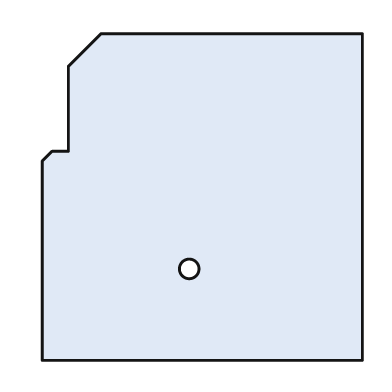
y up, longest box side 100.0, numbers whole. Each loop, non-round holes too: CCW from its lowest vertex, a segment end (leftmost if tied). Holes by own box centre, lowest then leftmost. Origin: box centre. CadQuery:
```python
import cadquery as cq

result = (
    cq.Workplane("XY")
    .moveTo(-49.0, -50.0)
    .lineTo(49.0, -50.0)
    .lineTo(49.0, 50.0)
    .lineTo(-31.0, 50.0)
    .lineTo(-41.0, 40.0)
    .lineTo(-41.0, 14.0)
    .lineTo(-46.0, 14.0)
    .lineTo(-49.0, 11.0)
    .close()
    .moveTo(-4.0, -22.0)
    .circle(3.0)
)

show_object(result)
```